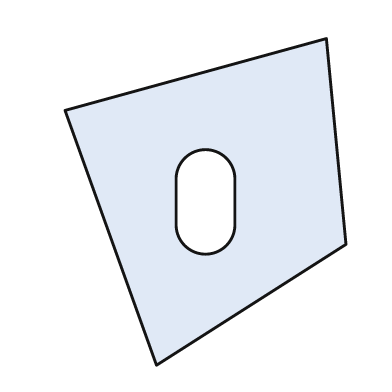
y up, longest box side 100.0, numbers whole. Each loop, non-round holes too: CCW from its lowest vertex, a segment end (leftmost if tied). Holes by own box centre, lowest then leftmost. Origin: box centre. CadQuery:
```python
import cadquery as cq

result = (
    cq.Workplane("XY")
    .moveTo(-15.0, -50.0)
    .lineTo(43.0, -13.0)
    .lineTo(37.0, 50.0)
    .lineTo(-43.0, 28.0)
    .close()
    .moveTo(-9.0, -7.0)
    .threePointArc((0.0, -16.0), (9.0, -7.0))
    .lineTo(9.0, 7.0)
    .threePointArc((0.0, 16.0), (-9.0, 7.0))
    .close()
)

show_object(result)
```